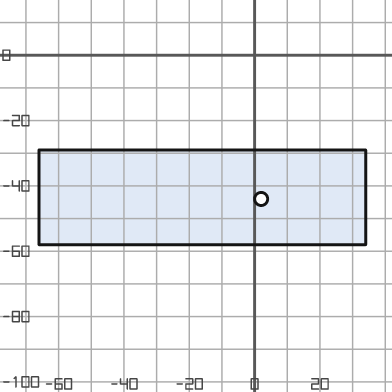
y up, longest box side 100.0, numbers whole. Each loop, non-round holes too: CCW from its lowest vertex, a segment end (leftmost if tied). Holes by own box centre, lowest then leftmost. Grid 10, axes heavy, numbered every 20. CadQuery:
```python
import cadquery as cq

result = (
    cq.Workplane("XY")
    .moveTo(-66.0, -58.0)
    .lineTo(34.0, -58.0)
    .lineTo(34.0, -29.0)
    .lineTo(-66.0, -29.0)
    .close()
    .moveTo(2.0, -44.0)
    .circle(2.0)
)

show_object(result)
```